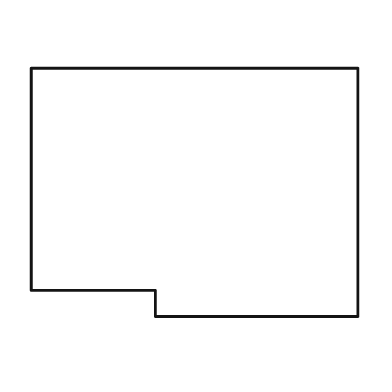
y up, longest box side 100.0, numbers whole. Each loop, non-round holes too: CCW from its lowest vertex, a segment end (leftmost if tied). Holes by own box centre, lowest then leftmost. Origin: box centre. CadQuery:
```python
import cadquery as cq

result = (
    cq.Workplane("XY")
    .moveTo(-12.0, -38.0)
    .lineTo(50.0, -38.0)
    .lineTo(50.0, 38.0)
    .lineTo(-50.0, 38.0)
    .lineTo(-50.0, -30.0)
    .lineTo(-12.0, -30.0)
    .close()
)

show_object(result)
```